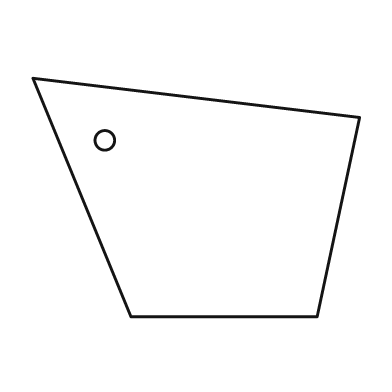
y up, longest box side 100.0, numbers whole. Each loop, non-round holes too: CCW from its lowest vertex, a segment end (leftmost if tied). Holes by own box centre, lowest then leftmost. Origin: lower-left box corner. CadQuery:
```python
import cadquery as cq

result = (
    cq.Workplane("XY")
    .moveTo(30.0, 0.0)
    .lineTo(87.0, 0.0)
    .lineTo(100.0, 61.0)
    .lineTo(0.0, 73.0)
    .close()
    .moveTo(22.0, 54.0)
    .circle(3.0)
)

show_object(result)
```